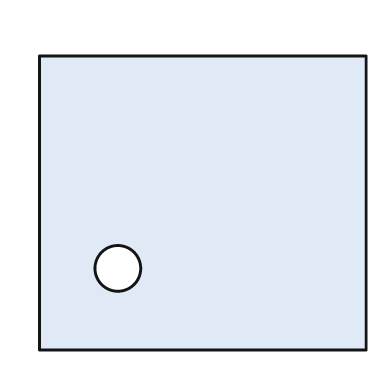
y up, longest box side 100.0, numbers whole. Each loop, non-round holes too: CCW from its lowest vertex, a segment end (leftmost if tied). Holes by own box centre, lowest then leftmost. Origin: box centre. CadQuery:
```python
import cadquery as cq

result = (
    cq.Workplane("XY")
    .moveTo(-50.0, -45.0)
    .lineTo(50.0, -45.0)
    .lineTo(50.0, 45.0)
    .lineTo(-50.0, 45.0)
    .close()
    .moveTo(-26.0, -20.0)
    .circle(7.0)
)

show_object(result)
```